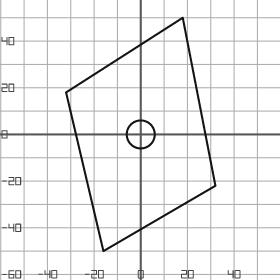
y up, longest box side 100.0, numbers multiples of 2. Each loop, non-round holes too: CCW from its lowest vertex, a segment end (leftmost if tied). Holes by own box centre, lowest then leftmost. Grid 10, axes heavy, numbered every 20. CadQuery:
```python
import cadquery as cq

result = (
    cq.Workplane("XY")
    .moveTo(-16.0, -50.0)
    .lineTo(32.0, -22.0)
    .lineTo(18.0, 50.0)
    .lineTo(-32.0, 18.0)
    .close()
    .moveTo(0.0, 0.0)
    .circle(6.0)
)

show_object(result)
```